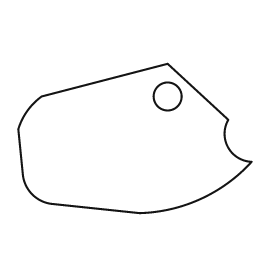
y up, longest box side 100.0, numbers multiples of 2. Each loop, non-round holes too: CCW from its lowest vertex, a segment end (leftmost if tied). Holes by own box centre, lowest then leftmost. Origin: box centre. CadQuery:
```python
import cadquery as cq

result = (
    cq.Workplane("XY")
    .moveTo(2.0, -32.0)
    .threePointArc((28.0, -26.0), (50.0, -10.0))
    .threePointArc((40.0, -4.0), (40.0, 8.0))
    .lineTo(14.0, 32.0)
    .lineTo(-40.0, 18.0)
    .threePointArc((-46.0, 12.0), (-50.0, 4.0))
    .lineTo(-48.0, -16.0)
    .threePointArc((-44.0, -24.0), (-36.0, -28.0))
    .close()
    .moveTo(14.0, 18.0)
    .circle(6.0)
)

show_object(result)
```